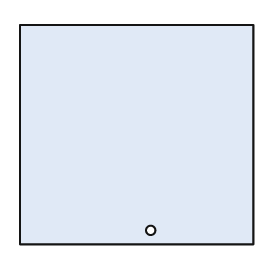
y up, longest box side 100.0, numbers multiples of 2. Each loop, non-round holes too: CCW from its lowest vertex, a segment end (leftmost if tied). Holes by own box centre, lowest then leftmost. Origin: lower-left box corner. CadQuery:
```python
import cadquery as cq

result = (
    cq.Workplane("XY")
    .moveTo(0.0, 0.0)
    .lineTo(100.0, 0.0)
    .lineTo(100.0, 94.0)
    .lineTo(0.0, 94.0)
    .close()
    .moveTo(56.0, 6.0)
    .circle(2.0)
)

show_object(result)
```